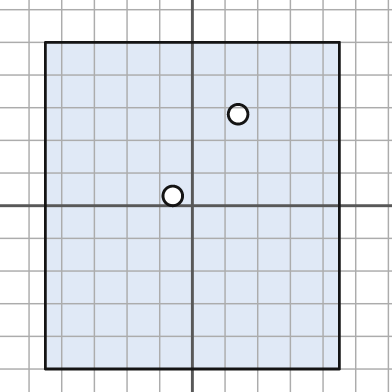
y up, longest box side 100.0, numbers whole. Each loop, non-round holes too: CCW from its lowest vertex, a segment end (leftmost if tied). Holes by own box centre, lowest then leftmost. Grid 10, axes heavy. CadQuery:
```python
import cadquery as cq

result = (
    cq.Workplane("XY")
    .moveTo(-45.0, -50.0)
    .lineTo(45.0, -50.0)
    .lineTo(45.0, 50.0)
    .lineTo(-45.0, 50.0)
    .close()
    .moveTo(-6.0, 3.0)
    .circle(3.0)
    .moveTo(14.0, 28.0)
    .circle(3.0)
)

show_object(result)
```